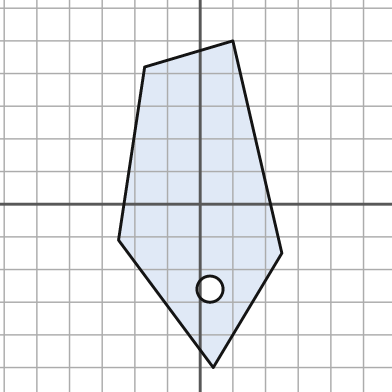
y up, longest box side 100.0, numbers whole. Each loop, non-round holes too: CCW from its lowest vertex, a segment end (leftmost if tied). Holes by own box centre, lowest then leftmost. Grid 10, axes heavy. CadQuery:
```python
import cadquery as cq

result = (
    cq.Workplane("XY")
    .moveTo(4.0, -50.0)
    .lineTo(25.0, -15.0)
    .lineTo(10.0, 50.0)
    .lineTo(-17.0, 42.0)
    .lineTo(-25.0, -11.0)
    .close()
    .moveTo(3.0, -26.0)
    .circle(4.0)
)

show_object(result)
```